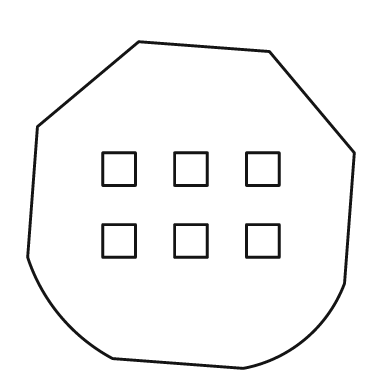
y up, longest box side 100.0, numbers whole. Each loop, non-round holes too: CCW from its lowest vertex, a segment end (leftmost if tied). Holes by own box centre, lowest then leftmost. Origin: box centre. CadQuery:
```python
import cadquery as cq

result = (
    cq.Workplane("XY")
    .moveTo(16.0, -50.0)
    .threePointArc((35.0, -41.0), (47.0, -24.0))
    .lineTo(50.0, 16.0)
    .lineTo(24.0, 47.0)
    .lineTo(-16.0, 50.0)
    .lineTo(-47.0, 24.0)
    .lineTo(-50.0, -16.0)
    .threePointArc((-40.0, -34.0), (-24.0, -47.0))
    .close()
    .moveTo(-27.0, -16.0)
    .lineTo(-17.0, -16.0)
    .lineTo(-17.0, -6.0)
    .lineTo(-27.0, -6.0)
    .close()
    .moveTo(-5.0, -16.0)
    .lineTo(5.0, -16.0)
    .lineTo(5.0, -6.0)
    .lineTo(-5.0, -6.0)
    .close()
    .moveTo(17.0, -16.0)
    .lineTo(27.0, -16.0)
    .lineTo(27.0, -6.0)
    .lineTo(17.0, -6.0)
    .close()
    .moveTo(-27.0, 6.0)
    .lineTo(-17.0, 6.0)
    .lineTo(-17.0, 16.0)
    .lineTo(-27.0, 16.0)
    .close()
    .moveTo(-5.0, 6.0)
    .lineTo(5.0, 6.0)
    .lineTo(5.0, 16.0)
    .lineTo(-5.0, 16.0)
    .close()
    .moveTo(17.0, 6.0)
    .lineTo(27.0, 6.0)
    .lineTo(27.0, 16.0)
    .lineTo(17.0, 16.0)
    .close()
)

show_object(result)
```